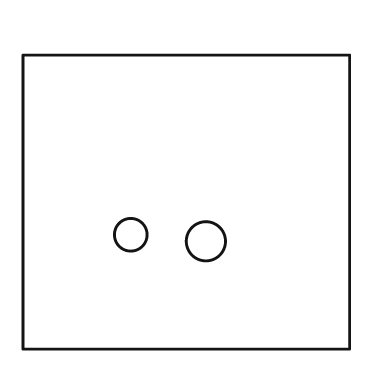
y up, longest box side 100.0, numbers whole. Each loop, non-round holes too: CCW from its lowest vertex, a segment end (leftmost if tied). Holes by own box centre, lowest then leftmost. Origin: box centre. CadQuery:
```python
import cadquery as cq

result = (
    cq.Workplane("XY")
    .moveTo(-50.0, -45.0)
    .lineTo(50.0, -45.0)
    .lineTo(50.0, 45.0)
    .lineTo(-50.0, 45.0)
    .close()
    .moveTo(6.0, -12.0)
    .circle(6.0)
    .moveTo(-17.0, -10.0)
    .circle(5.0)
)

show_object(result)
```